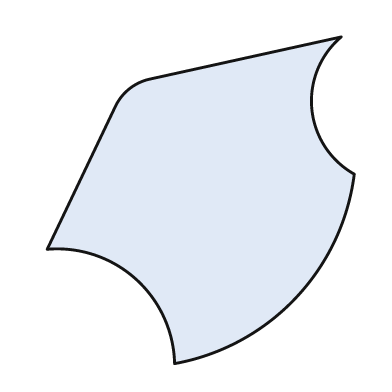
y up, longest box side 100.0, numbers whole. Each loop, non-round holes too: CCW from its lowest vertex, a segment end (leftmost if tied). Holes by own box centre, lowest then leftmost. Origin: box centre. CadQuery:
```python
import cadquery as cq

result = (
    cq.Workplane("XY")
    .moveTo(-8.0, -50.0)
    .threePointArc((29.0, -30.0), (47.0, 8.0))
    .threePointArc((34.0, 28.0), (43.0, 50.0))
    .lineTo(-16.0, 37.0)
    .threePointArc((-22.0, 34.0), (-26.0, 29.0))
    .lineTo(-47.0, -15.0)
    .threePointArc((-20.0, -24.0), (-8.0, -50.0))
    .close()
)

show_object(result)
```